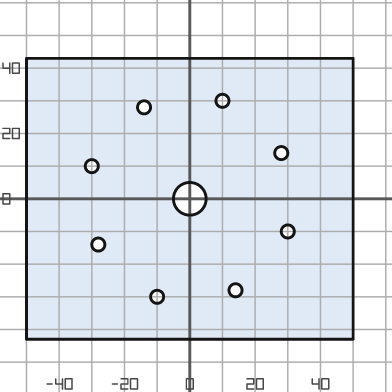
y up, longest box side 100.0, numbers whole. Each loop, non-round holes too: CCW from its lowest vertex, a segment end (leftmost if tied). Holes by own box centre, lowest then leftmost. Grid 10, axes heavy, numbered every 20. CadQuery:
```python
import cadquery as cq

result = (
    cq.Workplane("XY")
    .moveTo(-50.0, -43.0)
    .lineTo(50.0, -43.0)
    .lineTo(50.0, 43.0)
    .lineTo(-50.0, 43.0)
    .close()
    .moveTo(-10.0, -30.0)
    .circle(2.0)
    .moveTo(14.0, -28.0)
    .circle(2.0)
    .moveTo(-28.0, -14.0)
    .circle(2.0)
    .moveTo(30.0, -10.0)
    .circle(2.0)
    .moveTo(0.0, 0.0)
    .circle(5.0)
    .moveTo(-30.0, 10.0)
    .circle(2.0)
    .moveTo(28.0, 14.0)
    .circle(2.0)
    .moveTo(-14.0, 28.0)
    .circle(2.0)
    .moveTo(10.0, 30.0)
    .circle(2.0)
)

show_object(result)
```